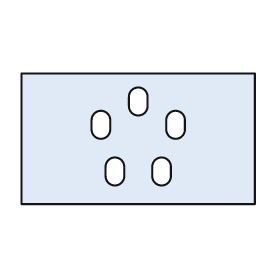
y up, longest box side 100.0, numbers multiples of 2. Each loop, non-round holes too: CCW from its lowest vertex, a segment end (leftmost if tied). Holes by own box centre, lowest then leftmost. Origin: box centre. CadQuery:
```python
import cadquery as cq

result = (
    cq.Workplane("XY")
    .moveTo(-50.0, -28.0)
    .lineTo(50.0, -28.0)
    .lineTo(50.0, 28.0)
    .lineTo(-50.0, 28.0)
    .close()
    .moveTo(-14.0, -16.0)
    .threePointArc((-10.0, -20.0), (-6.0, -16.0))
    .lineTo(-6.0, -12.0)
    .threePointArc((-10.0, -8.0), (-14.0, -12.0))
    .close()
    .moveTo(6.0, -16.0)
    .threePointArc((10.0, -20.0), (14.0, -16.0))
    .lineTo(14.0, -12.0)
    .threePointArc((10.0, -8.0), (6.0, -12.0))
    .close()
    .moveTo(-20.0, 4.0)
    .threePointArc((-16.0, 0.0), (-12.0, 4.0))
    .lineTo(-12.0, 8.0)
    .threePointArc((-16.0, 12.0), (-20.0, 8.0))
    .close()
    .moveTo(12.0, 4.0)
    .threePointArc((16.0, 0.0), (20.0, 4.0))
    .lineTo(20.0, 8.0)
    .threePointArc((16.0, 12.0), (12.0, 8.0))
    .close()
    .moveTo(-4.0, 14.0)
    .threePointArc((0.0, 10.0), (4.0, 14.0))
    .lineTo(4.0, 18.0)
    .threePointArc((0.0, 22.0), (-4.0, 18.0))
    .close()
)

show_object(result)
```